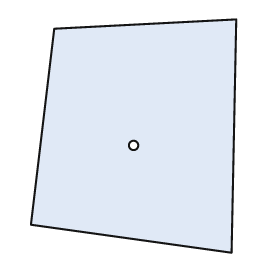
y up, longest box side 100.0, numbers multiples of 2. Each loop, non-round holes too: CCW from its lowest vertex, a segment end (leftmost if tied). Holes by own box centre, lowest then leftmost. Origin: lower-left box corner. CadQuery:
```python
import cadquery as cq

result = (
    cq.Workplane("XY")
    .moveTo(86.0, 0.0)
    .lineTo(88.0, 100.0)
    .lineTo(10.0, 96.0)
    .lineTo(0.0, 12.0)
    .close()
    .moveTo(44.0, 46.0)
    .circle(2.0)
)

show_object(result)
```